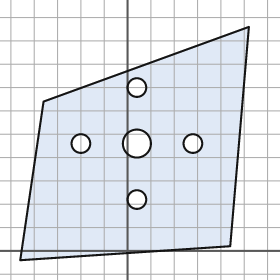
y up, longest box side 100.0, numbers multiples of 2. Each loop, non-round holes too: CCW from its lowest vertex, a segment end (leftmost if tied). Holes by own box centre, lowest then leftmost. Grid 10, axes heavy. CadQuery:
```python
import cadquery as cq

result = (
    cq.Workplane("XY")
    .moveTo(-46.0, -4.0)
    .lineTo(44.0, 2.0)
    .lineTo(52.0, 96.0)
    .lineTo(-36.0, 64.0)
    .close()
    .moveTo(4.0, 22.0)
    .circle(4.0)
    .moveTo(-20.0, 46.0)
    .circle(4.0)
    .moveTo(4.0, 46.0)
    .circle(6.0)
    .moveTo(28.0, 46.0)
    .circle(4.0)
    .moveTo(4.0, 70.0)
    .circle(4.0)
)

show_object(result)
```